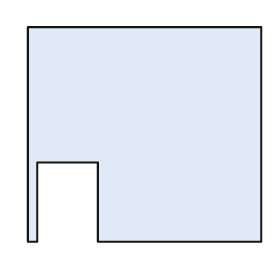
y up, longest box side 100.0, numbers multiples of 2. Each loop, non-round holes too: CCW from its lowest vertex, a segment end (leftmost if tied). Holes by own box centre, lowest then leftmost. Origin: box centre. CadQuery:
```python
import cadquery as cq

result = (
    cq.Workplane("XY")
    .moveTo(-50.0, -46.0)
    .lineTo(-46.0, -46.0)
    .lineTo(-46.0, -12.0)
    .lineTo(-20.0, -12.0)
    .lineTo(-20.0, -46.0)
    .lineTo(50.0, -46.0)
    .lineTo(50.0, 46.0)
    .lineTo(-50.0, 46.0)
    .close()
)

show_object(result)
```